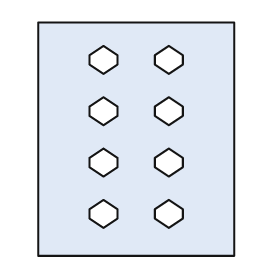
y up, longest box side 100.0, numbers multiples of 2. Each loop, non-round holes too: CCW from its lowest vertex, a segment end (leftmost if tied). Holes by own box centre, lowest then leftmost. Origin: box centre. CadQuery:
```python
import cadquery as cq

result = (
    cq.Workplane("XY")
    .moveTo(-42.0, -50.0)
    .lineTo(42.0, -50.0)
    .lineTo(42.0, 50.0)
    .lineTo(-42.0, 50.0)
    .close()
    .moveTo(-14.0, -38.0)
    .lineTo(-8.0, -34.0)
    .lineTo(-8.0, -30.0)
    .lineTo(-14.0, -26.0)
    .lineTo(-20.0, -30.0)
    .lineTo(-20.0, -34.0)
    .close()
    .moveTo(14.0, -38.0)
    .lineTo(20.0, -34.0)
    .lineTo(20.0, -30.0)
    .lineTo(14.0, -26.0)
    .lineTo(8.0, -30.0)
    .lineTo(8.0, -34.0)
    .close()
    .moveTo(-14.0, -16.0)
    .lineTo(-8.0, -12.0)
    .lineTo(-8.0, -8.0)
    .lineTo(-14.0, -4.0)
    .lineTo(-20.0, -8.0)
    .lineTo(-20.0, -12.0)
    .close()
    .moveTo(14.0, -16.0)
    .lineTo(20.0, -12.0)
    .lineTo(20.0, -8.0)
    .lineTo(14.0, -4.0)
    .lineTo(8.0, -8.0)
    .lineTo(8.0, -12.0)
    .close()
    .moveTo(-14.0, 6.0)
    .lineTo(-8.0, 10.0)
    .lineTo(-8.0, 14.0)
    .lineTo(-14.0, 18.0)
    .lineTo(-20.0, 14.0)
    .lineTo(-20.0, 10.0)
    .close()
    .moveTo(14.0, 6.0)
    .lineTo(20.0, 10.0)
    .lineTo(20.0, 14.0)
    .lineTo(14.0, 18.0)
    .lineTo(8.0, 14.0)
    .lineTo(8.0, 10.0)
    .close()
    .moveTo(-14.0, 28.0)
    .lineTo(-8.0, 32.0)
    .lineTo(-8.0, 36.0)
    .lineTo(-14.0, 40.0)
    .lineTo(-20.0, 36.0)
    .lineTo(-20.0, 32.0)
    .close()
    .moveTo(14.0, 28.0)
    .lineTo(20.0, 32.0)
    .lineTo(20.0, 36.0)
    .lineTo(14.0, 40.0)
    .lineTo(8.0, 36.0)
    .lineTo(8.0, 32.0)
    .close()
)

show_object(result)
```